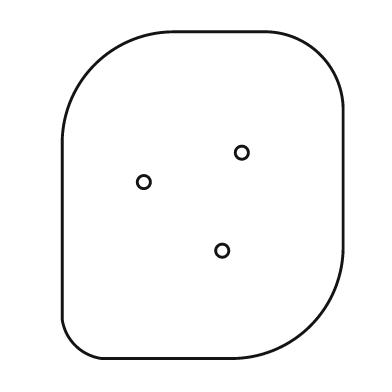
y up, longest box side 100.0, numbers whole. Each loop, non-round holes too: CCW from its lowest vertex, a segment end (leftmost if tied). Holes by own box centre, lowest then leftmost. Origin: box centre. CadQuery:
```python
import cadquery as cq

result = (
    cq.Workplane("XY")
    .moveTo(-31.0, -50.0)
    .lineTo(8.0, -50.0)
    .threePointArc((33.0, -40.0), (43.0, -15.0))
    .lineTo(43.0, 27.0)
    .threePointArc((36.0, 43.0), (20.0, 50.0))
    .lineTo(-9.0, 50.0)
    .threePointArc((-33.0, 40.0), (-43.0, 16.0))
    .lineTo(-43.0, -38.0)
    .threePointArc((-39.0, -46.0), (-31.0, -50.0))
    .close()
    .moveTo(6.0, -17.0)
    .circle(2.0)
    .moveTo(-18.0, 4.0)
    .circle(2.0)
    .moveTo(12.0, 13.0)
    .circle(2.0)
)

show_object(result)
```